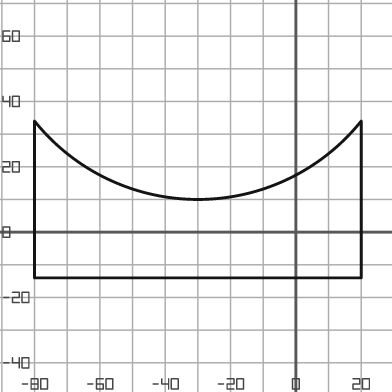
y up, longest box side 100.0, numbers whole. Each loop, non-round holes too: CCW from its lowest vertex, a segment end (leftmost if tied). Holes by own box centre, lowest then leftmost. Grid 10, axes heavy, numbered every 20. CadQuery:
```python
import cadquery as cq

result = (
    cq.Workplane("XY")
    .moveTo(-80.0, -14.0)
    .lineTo(20.0, -14.0)
    .lineTo(20.0, 34.0)
    .threePointArc((-30.0, 10.0), (-80.0, 34.0))
    .close()
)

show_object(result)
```